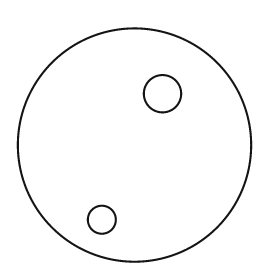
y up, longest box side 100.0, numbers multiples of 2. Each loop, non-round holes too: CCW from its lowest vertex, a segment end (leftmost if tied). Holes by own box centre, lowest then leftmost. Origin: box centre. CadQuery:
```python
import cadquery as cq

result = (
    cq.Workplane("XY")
    .moveTo(0.0, 0.0)
    .circle(50.0)
    .moveTo(-14.0, -32.0)
    .circle(6.0)
    .moveTo(12.0, 22.0)
    .circle(8.0)
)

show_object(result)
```